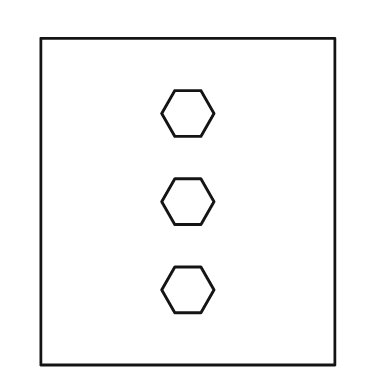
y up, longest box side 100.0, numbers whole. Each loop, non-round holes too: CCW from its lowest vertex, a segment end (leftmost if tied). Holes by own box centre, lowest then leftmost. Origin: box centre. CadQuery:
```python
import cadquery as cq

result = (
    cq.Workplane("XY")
    .moveTo(-45.0, -50.0)
    .lineTo(45.0, -50.0)
    .lineTo(45.0, 50.0)
    .lineTo(-45.0, 50.0)
    .close()
    .moveTo(-4.0, -34.0)
    .lineTo(4.0, -34.0)
    .lineTo(8.0, -27.0)
    .lineTo(4.0, -20.0)
    .lineTo(-4.0, -20.0)
    .lineTo(-8.0, -27.0)
    .close()
    .moveTo(-4.0, -7.0)
    .lineTo(4.0, -7.0)
    .lineTo(8.0, 0.0)
    .lineTo(4.0, 7.0)
    .lineTo(-4.0, 7.0)
    .lineTo(-8.0, 0.0)
    .close()
    .moveTo(-4.0, 20.0)
    .lineTo(4.0, 20.0)
    .lineTo(8.0, 27.0)
    .lineTo(4.0, 34.0)
    .lineTo(-4.0, 34.0)
    .lineTo(-8.0, 27.0)
    .close()
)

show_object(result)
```